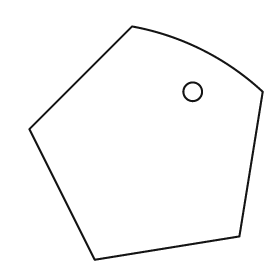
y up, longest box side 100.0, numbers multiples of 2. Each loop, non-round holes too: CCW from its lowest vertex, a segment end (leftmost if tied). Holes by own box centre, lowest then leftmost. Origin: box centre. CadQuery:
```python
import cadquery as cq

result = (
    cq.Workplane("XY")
    .moveTo(-22.0, -50.0)
    .lineTo(40.0, -40.0)
    .lineTo(50.0, 22.0)
    .threePointArc((24.0, 40.0), (-6.0, 50.0))
    .lineTo(-50.0, 6.0)
    .close()
    .moveTo(20.0, 22.0)
    .circle(4.0)
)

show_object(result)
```